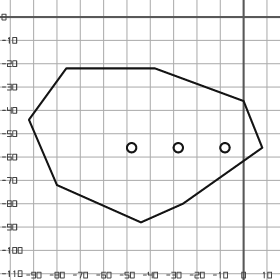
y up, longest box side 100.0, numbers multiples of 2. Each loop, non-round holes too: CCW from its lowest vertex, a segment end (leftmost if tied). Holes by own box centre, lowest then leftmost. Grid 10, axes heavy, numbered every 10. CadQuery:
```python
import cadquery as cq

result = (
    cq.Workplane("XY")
    .moveTo(-44.0, -88.0)
    .lineTo(-26.0, -80.0)
    .lineTo(8.0, -56.0)
    .lineTo(0.0, -36.0)
    .lineTo(-38.0, -22.0)
    .lineTo(-76.0, -22.0)
    .lineTo(-92.0, -44.0)
    .lineTo(-80.0, -72.0)
    .close()
    .moveTo(-48.0, -56.0)
    .circle(2.0)
    .moveTo(-28.0, -56.0)
    .circle(2.0)
    .moveTo(-8.0, -56.0)
    .circle(2.0)
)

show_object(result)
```